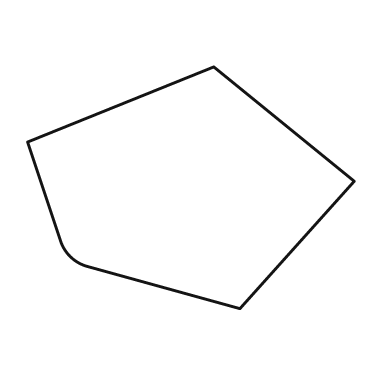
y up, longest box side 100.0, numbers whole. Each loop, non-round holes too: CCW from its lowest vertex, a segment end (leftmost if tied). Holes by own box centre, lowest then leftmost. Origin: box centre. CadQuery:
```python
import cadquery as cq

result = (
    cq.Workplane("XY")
    .moveTo(15.0, -37.0)
    .lineTo(50.0, 2.0)
    .lineTo(7.0, 37.0)
    .lineTo(-50.0, 14.0)
    .lineTo(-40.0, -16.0)
    .threePointArc((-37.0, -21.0), (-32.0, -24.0))
    .close()
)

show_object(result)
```